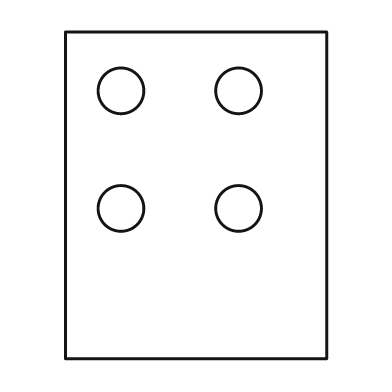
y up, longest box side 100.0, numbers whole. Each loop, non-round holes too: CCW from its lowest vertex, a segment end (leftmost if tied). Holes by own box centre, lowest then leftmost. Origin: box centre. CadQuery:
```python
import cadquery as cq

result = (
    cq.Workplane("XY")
    .moveTo(-40.0, -50.0)
    .lineTo(40.0, -50.0)
    .lineTo(40.0, 50.0)
    .lineTo(-40.0, 50.0)
    .close()
    .moveTo(-23.0, -4.0)
    .circle(7.0)
    .moveTo(13.0, -4.0)
    .circle(7.0)
    .moveTo(-23.0, 32.0)
    .circle(7.0)
    .moveTo(13.0, 32.0)
    .circle(7.0)
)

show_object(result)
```